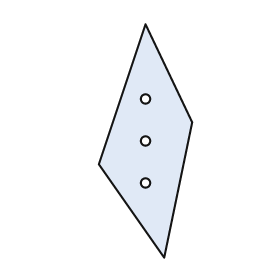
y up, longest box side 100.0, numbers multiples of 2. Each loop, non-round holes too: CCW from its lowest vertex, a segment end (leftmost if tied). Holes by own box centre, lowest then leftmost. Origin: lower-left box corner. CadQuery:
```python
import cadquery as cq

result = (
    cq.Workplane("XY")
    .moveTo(28.0, 0.0)
    .lineTo(40.0, 58.0)
    .lineTo(20.0, 100.0)
    .lineTo(0.0, 40.0)
    .close()
    .moveTo(20.0, 32.0)
    .circle(2.0)
    .moveTo(20.0, 50.0)
    .circle(2.0)
    .moveTo(20.0, 68.0)
    .circle(2.0)
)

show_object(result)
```